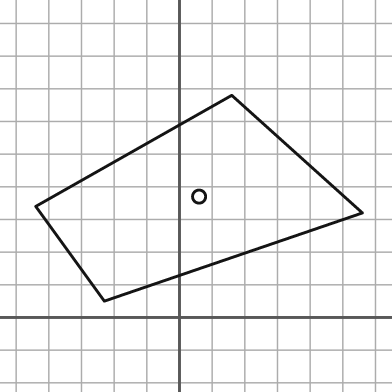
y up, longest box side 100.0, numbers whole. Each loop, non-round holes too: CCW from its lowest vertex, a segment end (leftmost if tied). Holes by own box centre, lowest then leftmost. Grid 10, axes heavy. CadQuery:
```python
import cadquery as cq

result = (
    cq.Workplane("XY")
    .moveTo(-23.0, 5.0)
    .lineTo(56.0, 32.0)
    .lineTo(16.0, 68.0)
    .lineTo(-44.0, 34.0)
    .close()
    .moveTo(6.0, 37.0)
    .circle(2.0)
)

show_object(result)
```